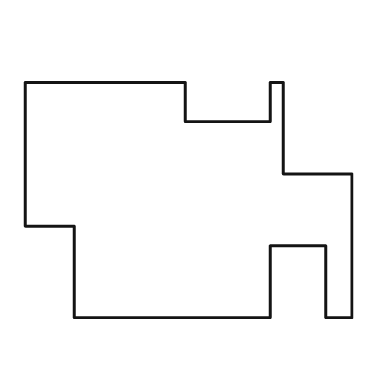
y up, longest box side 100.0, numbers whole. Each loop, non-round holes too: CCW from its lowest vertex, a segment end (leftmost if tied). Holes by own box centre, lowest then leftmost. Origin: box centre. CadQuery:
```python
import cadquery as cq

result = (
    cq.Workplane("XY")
    .moveTo(-35.0, -36.0)
    .lineTo(25.0, -36.0)
    .lineTo(25.0, -14.0)
    .lineTo(42.0, -14.0)
    .lineTo(42.0, -36.0)
    .lineTo(50.0, -36.0)
    .lineTo(50.0, 8.0)
    .lineTo(29.0, 8.0)
    .lineTo(29.0, 36.0)
    .lineTo(25.0, 36.0)
    .lineTo(25.0, 24.0)
    .lineTo(-1.0, 24.0)
    .lineTo(-1.0, 36.0)
    .lineTo(-50.0, 36.0)
    .lineTo(-50.0, -8.0)
    .lineTo(-35.0, -8.0)
    .close()
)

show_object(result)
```